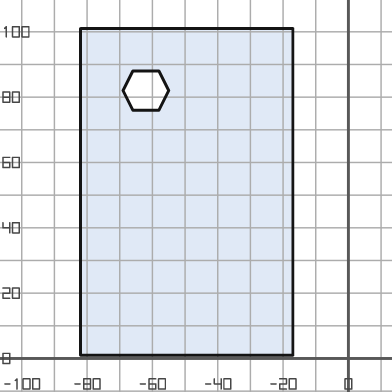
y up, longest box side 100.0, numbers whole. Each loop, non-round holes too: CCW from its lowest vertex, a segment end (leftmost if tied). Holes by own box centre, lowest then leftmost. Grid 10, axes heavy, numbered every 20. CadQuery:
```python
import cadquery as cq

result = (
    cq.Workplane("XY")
    .moveTo(-82.0, 1.0)
    .lineTo(-17.0, 1.0)
    .lineTo(-17.0, 101.0)
    .lineTo(-82.0, 101.0)
    .close()
    .moveTo(-66.0, 76.0)
    .lineTo(-58.0, 76.0)
    .lineTo(-55.0, 82.0)
    .lineTo(-58.0, 88.0)
    .lineTo(-66.0, 88.0)
    .lineTo(-69.0, 82.0)
    .close()
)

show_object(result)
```